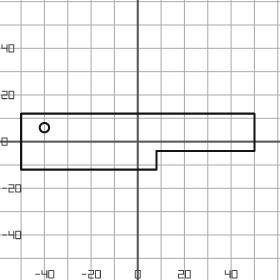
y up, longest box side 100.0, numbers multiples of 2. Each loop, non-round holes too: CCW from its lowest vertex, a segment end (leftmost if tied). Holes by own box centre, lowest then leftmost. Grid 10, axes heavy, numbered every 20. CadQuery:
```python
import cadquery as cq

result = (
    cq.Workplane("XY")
    .moveTo(-50.0, -12.0)
    .lineTo(8.0, -12.0)
    .lineTo(8.0, -4.0)
    .lineTo(50.0, -4.0)
    .lineTo(50.0, 12.0)
    .lineTo(-50.0, 12.0)
    .close()
    .moveTo(-40.0, 6.0)
    .circle(2.0)
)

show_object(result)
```